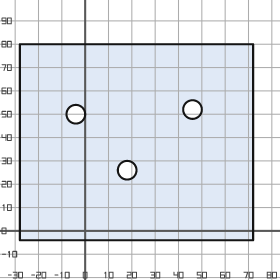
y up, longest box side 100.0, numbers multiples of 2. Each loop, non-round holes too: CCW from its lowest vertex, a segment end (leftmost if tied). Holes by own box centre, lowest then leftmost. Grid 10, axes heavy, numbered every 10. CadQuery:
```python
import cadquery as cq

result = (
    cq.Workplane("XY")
    .moveTo(-28.0, -4.0)
    .lineTo(72.0, -4.0)
    .lineTo(72.0, 80.0)
    .lineTo(-28.0, 80.0)
    .close()
    .moveTo(18.0, 26.0)
    .circle(4.0)
    .moveTo(-4.0, 50.0)
    .circle(4.0)
    .moveTo(46.0, 52.0)
    .circle(4.0)
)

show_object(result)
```